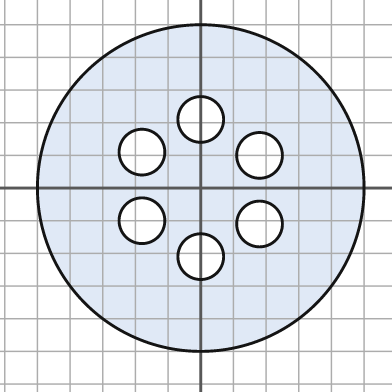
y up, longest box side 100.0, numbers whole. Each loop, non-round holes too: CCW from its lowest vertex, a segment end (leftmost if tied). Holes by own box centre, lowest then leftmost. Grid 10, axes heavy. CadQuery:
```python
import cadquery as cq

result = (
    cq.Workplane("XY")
    .moveTo(0.0, 0.0)
    .circle(50.0)
    .moveTo(0.0, -21.0)
    .circle(7.0)
    .moveTo(18.0, -11.0)
    .circle(7.0)
    .moveTo(-18.0, -10.0)
    .circle(7.0)
    .moveTo(18.0, 10.0)
    .circle(7.0)
    .moveTo(-18.0, 11.0)
    .circle(7.0)
    .moveTo(0.0, 21.0)
    .circle(7.0)
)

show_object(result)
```